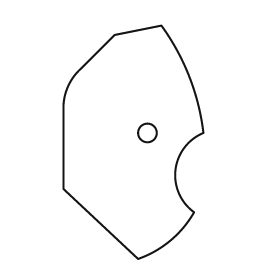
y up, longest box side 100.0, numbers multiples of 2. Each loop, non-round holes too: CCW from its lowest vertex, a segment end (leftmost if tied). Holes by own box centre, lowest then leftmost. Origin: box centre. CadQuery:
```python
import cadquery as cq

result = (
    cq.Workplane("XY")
    .moveTo(2.0, -50.0)
    .threePointArc((16.0, -42.0), (26.0, -30.0))
    .threePointArc((18.0, -12.0), (30.0, 4.0))
    .threePointArc((24.0, 28.0), (12.0, 50.0))
    .lineTo(-8.0, 46.0)
    .lineTo(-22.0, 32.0)
    .threePointArc((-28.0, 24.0), (-30.0, 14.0))
    .lineTo(-30.0, -20.0)
    .close()
    .moveTo(6.0, 4.0)
    .circle(4.0)
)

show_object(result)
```